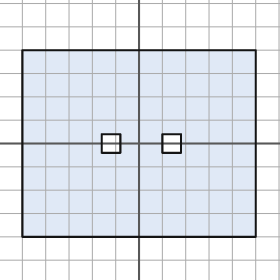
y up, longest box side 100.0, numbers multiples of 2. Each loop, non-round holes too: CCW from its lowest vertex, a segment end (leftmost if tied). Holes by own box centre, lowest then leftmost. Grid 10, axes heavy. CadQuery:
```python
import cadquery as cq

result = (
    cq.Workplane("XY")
    .moveTo(-50.0, -40.0)
    .lineTo(50.0, -40.0)
    .lineTo(50.0, 40.0)
    .lineTo(-50.0, 40.0)
    .close()
    .moveTo(-16.0, -4.0)
    .lineTo(-8.0, -4.0)
    .lineTo(-8.0, 4.0)
    .lineTo(-16.0, 4.0)
    .close()
    .moveTo(10.0, -4.0)
    .lineTo(18.0, -4.0)
    .lineTo(18.0, 4.0)
    .lineTo(10.0, 4.0)
    .close()
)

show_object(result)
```